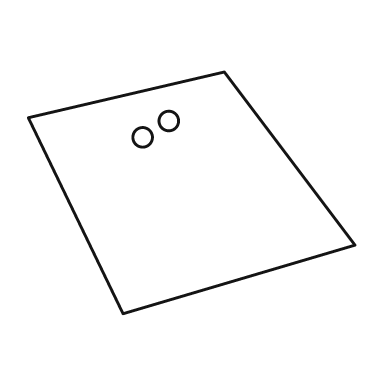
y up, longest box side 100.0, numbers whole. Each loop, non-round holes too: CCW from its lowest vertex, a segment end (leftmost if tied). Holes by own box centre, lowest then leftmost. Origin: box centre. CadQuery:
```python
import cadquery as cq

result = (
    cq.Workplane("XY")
    .moveTo(-21.0, -37.0)
    .lineTo(50.0, -16.0)
    .lineTo(10.0, 37.0)
    .lineTo(-50.0, 23.0)
    .close()
    .moveTo(-15.0, 17.0)
    .circle(3.0)
    .moveTo(-7.0, 22.0)
    .circle(3.0)
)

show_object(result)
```